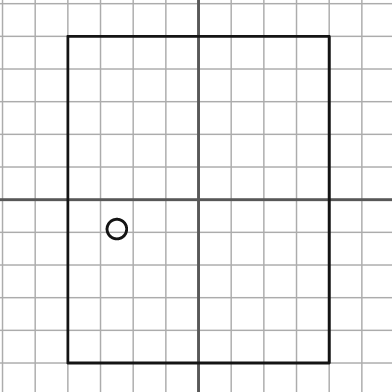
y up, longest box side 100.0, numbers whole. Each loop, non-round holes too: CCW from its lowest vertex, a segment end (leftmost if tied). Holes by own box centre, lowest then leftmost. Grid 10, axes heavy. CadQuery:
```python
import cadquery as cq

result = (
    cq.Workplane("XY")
    .moveTo(-40.0, -50.0)
    .lineTo(40.0, -50.0)
    .lineTo(40.0, 50.0)
    .lineTo(-40.0, 50.0)
    .close()
    .moveTo(-25.0, -9.0)
    .circle(3.0)
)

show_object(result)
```